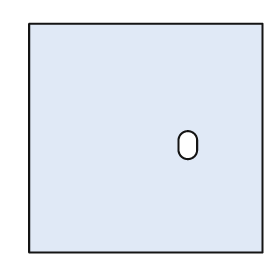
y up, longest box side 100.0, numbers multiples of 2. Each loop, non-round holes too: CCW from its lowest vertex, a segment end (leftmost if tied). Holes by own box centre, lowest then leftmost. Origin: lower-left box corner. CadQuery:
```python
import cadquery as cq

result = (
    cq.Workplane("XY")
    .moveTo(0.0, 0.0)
    .lineTo(100.0, 0.0)
    .lineTo(100.0, 98.0)
    .lineTo(0.0, 98.0)
    .close()
    .moveTo(64.0, 44.0)
    .threePointArc((68.0, 40.0), (72.0, 44.0))
    .lineTo(72.0, 48.0)
    .threePointArc((68.0, 52.0), (64.0, 48.0))
    .close()
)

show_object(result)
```